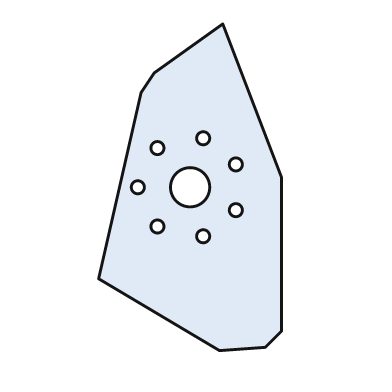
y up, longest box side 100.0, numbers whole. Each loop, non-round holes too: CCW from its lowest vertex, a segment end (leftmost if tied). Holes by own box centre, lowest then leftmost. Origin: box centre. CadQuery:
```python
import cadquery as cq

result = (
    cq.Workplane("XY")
    .moveTo(9.0, -50.0)
    .lineTo(23.0, -49.0)
    .lineTo(28.0, -44.0)
    .lineTo(28.0, 3.0)
    .lineTo(10.0, 50.0)
    .lineTo(-11.0, 35.0)
    .lineTo(-15.0, 29.0)
    .lineTo(-28.0, -28.0)
    .close()
    .moveTo(4.0, -15.0)
    .circle(2.0)
    .moveTo(-10.0, -12.0)
    .circle(2.0)
    .moveTo(14.0, -7.0)
    .circle(2.0)
    .moveTo(-16.0, 0.0)
    .circle(2.0)
    .moveTo(0.0, 0.0)
    .circle(6.0)
    .moveTo(14.0, 7.0)
    .circle(2.0)
    .moveTo(-10.0, 12.0)
    .circle(2.0)
    .moveTo(4.0, 15.0)
    .circle(2.0)
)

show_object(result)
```